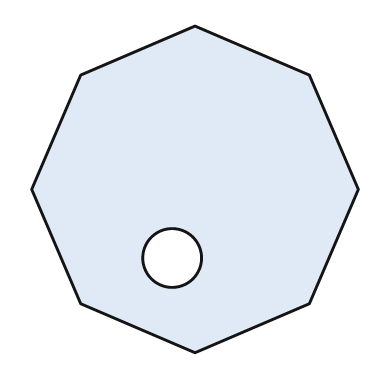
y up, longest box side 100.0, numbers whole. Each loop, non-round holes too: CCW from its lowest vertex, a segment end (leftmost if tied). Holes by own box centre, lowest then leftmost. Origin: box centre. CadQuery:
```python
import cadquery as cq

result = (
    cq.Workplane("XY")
    .moveTo(0.0, -50.0)
    .lineTo(35.0, -35.0)
    .lineTo(50.0, 0.0)
    .lineTo(35.0, 35.0)
    .lineTo(0.0, 50.0)
    .lineTo(-35.0, 35.0)
    .lineTo(-50.0, 0.0)
    .lineTo(-35.0, -35.0)
    .close()
    .moveTo(-7.0, -21.0)
    .circle(9.0)
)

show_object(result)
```